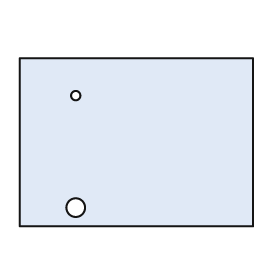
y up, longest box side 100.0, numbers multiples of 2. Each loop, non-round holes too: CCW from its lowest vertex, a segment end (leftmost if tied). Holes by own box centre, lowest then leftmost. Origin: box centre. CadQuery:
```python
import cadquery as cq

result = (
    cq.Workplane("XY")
    .moveTo(-50.0, -36.0)
    .lineTo(50.0, -36.0)
    .lineTo(50.0, 36.0)
    .lineTo(-50.0, 36.0)
    .close()
    .moveTo(-26.0, -28.0)
    .circle(4.0)
    .moveTo(-26.0, 20.0)
    .circle(2.0)
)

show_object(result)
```